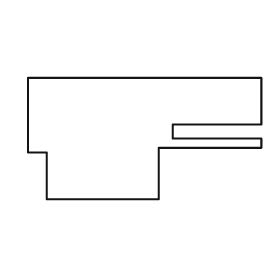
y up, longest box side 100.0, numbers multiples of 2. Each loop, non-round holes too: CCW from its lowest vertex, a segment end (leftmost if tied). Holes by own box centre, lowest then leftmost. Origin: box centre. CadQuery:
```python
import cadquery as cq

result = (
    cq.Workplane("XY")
    .moveTo(-42.0, -26.0)
    .lineTo(6.0, -26.0)
    .lineTo(6.0, -4.0)
    .lineTo(50.0, -4.0)
    .lineTo(50.0, 0.0)
    .lineTo(12.0, 0.0)
    .lineTo(12.0, 6.0)
    .lineTo(50.0, 6.0)
    .lineTo(50.0, 26.0)
    .lineTo(-50.0, 26.0)
    .lineTo(-50.0, -6.0)
    .lineTo(-42.0, -6.0)
    .close()
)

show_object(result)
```